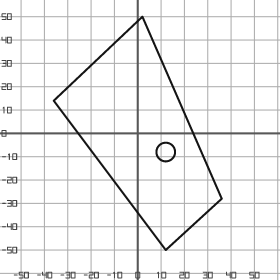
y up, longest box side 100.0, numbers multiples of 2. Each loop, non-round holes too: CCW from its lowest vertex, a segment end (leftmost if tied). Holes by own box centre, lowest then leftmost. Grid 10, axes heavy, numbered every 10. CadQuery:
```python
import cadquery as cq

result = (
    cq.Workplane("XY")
    .moveTo(12.0, -50.0)
    .lineTo(36.0, -28.0)
    .lineTo(2.0, 50.0)
    .lineTo(-36.0, 14.0)
    .close()
    .moveTo(12.0, -8.0)
    .circle(4.0)
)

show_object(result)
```